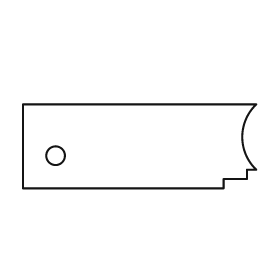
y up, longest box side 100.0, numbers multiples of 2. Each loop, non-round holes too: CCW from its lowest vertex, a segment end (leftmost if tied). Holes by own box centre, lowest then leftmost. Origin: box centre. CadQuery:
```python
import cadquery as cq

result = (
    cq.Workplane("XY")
    .moveTo(-50.0, -18.0)
    .lineTo(36.0, -18.0)
    .lineTo(36.0, -14.0)
    .lineTo(46.0, -14.0)
    .lineTo(46.0, -10.0)
    .lineTo(50.0, -10.0)
    .threePointArc((44.0, 4.0), (50.0, 18.0))
    .lineTo(-50.0, 18.0)
    .close()
    .moveTo(-36.0, -4.0)
    .circle(4.0)
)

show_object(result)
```